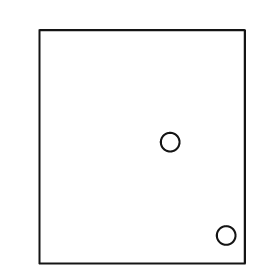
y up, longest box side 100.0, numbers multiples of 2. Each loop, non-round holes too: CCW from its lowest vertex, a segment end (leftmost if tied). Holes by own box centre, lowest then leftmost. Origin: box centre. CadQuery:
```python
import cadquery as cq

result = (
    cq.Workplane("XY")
    .moveTo(-44.0, -50.0)
    .lineTo(44.0, -50.0)
    .lineTo(44.0, 50.0)
    .lineTo(-44.0, 50.0)
    .close()
    .moveTo(36.0, -38.0)
    .circle(4.0)
    .moveTo(12.0, 2.0)
    .circle(4.0)
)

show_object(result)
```